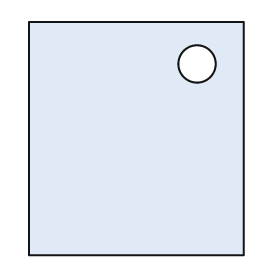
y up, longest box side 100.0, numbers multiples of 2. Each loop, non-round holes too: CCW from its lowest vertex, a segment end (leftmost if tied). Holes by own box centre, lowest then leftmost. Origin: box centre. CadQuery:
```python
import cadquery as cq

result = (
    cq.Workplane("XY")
    .moveTo(-46.0, -50.0)
    .lineTo(46.0, -50.0)
    .lineTo(46.0, 50.0)
    .lineTo(-46.0, 50.0)
    .close()
    .moveTo(26.0, 32.0)
    .circle(8.0)
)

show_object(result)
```